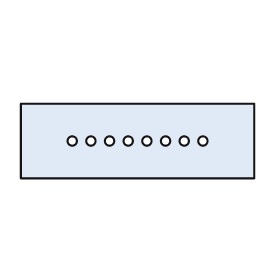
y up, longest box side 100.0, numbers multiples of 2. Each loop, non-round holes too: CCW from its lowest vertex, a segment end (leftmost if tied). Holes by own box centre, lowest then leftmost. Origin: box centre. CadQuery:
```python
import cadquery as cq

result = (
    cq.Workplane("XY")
    .moveTo(-50.0, -16.0)
    .lineTo(50.0, -16.0)
    .lineTo(50.0, 16.0)
    .lineTo(-50.0, 16.0)
    .close()
    .moveTo(-28.0, 0.0)
    .circle(2.0)
    .moveTo(-20.0, 0.0)
    .circle(2.0)
    .moveTo(-12.0, 0.0)
    .circle(2.0)
    .moveTo(-4.0, 0.0)
    .circle(2.0)
    .moveTo(4.0, 0.0)
    .circle(2.0)
    .moveTo(12.0, 0.0)
    .circle(2.0)
    .moveTo(20.0, 0.0)
    .circle(2.0)
    .moveTo(28.0, 0.0)
    .circle(2.0)
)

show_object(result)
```